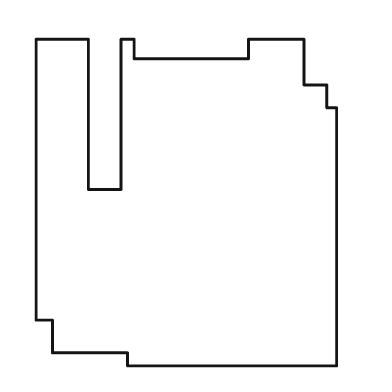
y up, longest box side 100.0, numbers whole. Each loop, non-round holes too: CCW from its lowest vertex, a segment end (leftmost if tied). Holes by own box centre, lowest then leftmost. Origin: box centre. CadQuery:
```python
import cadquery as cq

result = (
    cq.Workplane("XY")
    .moveTo(-18.0, -50.0)
    .lineTo(46.0, -50.0)
    .lineTo(46.0, 29.0)
    .lineTo(43.0, 29.0)
    .lineTo(43.0, 36.0)
    .lineTo(36.0, 36.0)
    .lineTo(36.0, 50.0)
    .lineTo(19.0, 50.0)
    .lineTo(19.0, 44.0)
    .lineTo(-16.0, 44.0)
    .lineTo(-16.0, 50.0)
    .lineTo(-20.0, 50.0)
    .lineTo(-20.0, 4.0)
    .lineTo(-30.0, 4.0)
    .lineTo(-30.0, 50.0)
    .lineTo(-46.0, 50.0)
    .lineTo(-46.0, -36.0)
    .lineTo(-41.0, -36.0)
    .lineTo(-41.0, -46.0)
    .lineTo(-18.0, -46.0)
    .close()
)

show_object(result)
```